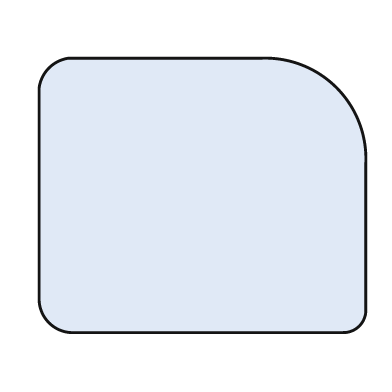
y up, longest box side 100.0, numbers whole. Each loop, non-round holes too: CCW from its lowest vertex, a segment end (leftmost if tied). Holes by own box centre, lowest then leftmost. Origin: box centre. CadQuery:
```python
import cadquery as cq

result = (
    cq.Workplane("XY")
    .moveTo(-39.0, -42.0)
    .lineTo(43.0, -42.0)
    .threePointArc((48.0, -40.0), (50.0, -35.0))
    .lineTo(50.0, 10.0)
    .threePointArc((41.0, 33.0), (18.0, 42.0))
    .lineTo(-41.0, 42.0)
    .threePointArc((-47.0, 39.0), (-50.0, 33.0))
    .lineTo(-50.0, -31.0)
    .threePointArc((-47.0, -39.0), (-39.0, -42.0))
    .close()
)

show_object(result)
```